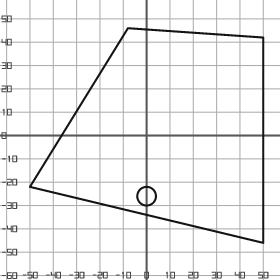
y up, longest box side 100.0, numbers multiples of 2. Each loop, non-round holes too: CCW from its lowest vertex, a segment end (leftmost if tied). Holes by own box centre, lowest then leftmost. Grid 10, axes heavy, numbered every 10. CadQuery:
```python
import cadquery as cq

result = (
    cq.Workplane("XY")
    .moveTo(50.0, -46.0)
    .lineTo(50.0, 42.0)
    .lineTo(-8.0, 46.0)
    .lineTo(-50.0, -22.0)
    .close()
    .moveTo(0.0, -26.0)
    .circle(4.0)
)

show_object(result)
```